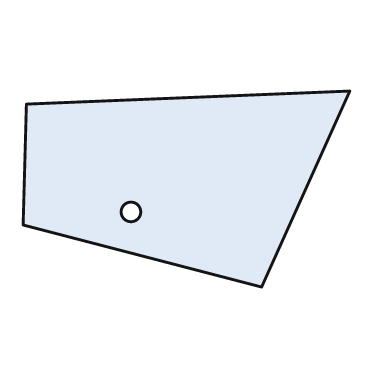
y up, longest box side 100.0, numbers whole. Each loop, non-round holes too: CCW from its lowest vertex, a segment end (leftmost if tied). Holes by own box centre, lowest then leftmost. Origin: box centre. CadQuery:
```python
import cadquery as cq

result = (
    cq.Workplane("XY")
    .moveTo(23.0, -30.0)
    .lineTo(50.0, 30.0)
    .lineTo(-49.0, 26.0)
    .lineTo(-50.0, -11.0)
    .close()
    .moveTo(-17.0, -7.0)
    .circle(3.0)
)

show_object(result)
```